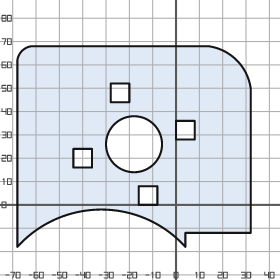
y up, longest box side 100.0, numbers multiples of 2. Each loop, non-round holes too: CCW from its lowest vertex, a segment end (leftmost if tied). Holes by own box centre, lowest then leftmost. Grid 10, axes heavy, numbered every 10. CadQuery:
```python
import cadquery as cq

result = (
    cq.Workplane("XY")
    .moveTo(-68.0, -18.0)
    .threePointArc((-32.0, -2.0), (4.0, -18.0))
    .lineTo(4.0, -12.0)
    .lineTo(32.0, -12.0)
    .lineTo(32.0, 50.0)
    .threePointArc((26.0, 62.0), (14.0, 68.0))
    .lineTo(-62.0, 68.0)
    .threePointArc((-66.0, 66.0), (-68.0, 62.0))
    .close()
    .moveTo(-16.0, 0.0)
    .lineTo(-8.0, 0.0)
    .lineTo(-8.0, 8.0)
    .lineTo(-16.0, 8.0)
    .close()
    .moveTo(-44.0, 16.0)
    .lineTo(-36.0, 16.0)
    .lineTo(-36.0, 24.0)
    .lineTo(-44.0, 24.0)
    .close()
    .moveTo(-18.0, 26.0)
    .circle(12.0)
    .moveTo(0.0, 28.0)
    .lineTo(8.0, 28.0)
    .lineTo(8.0, 36.0)
    .lineTo(0.0, 36.0)
    .close()
    .moveTo(-28.0, 44.0)
    .lineTo(-20.0, 44.0)
    .lineTo(-20.0, 52.0)
    .lineTo(-28.0, 52.0)
    .close()
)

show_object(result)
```